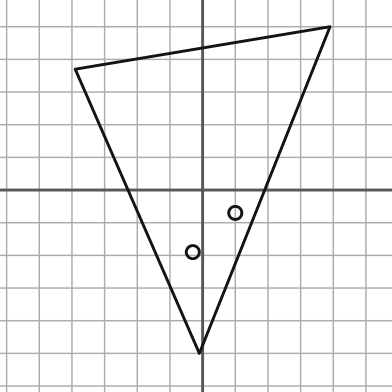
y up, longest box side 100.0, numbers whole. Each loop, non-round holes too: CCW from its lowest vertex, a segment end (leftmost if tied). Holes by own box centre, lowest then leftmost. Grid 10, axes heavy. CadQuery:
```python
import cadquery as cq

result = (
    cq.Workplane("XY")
    .moveTo(-1.0, -50.0)
    .lineTo(39.0, 50.0)
    .lineTo(-39.0, 37.0)
    .close()
    .moveTo(-3.0, -19.0)
    .circle(2.0)
    .moveTo(10.0, -7.0)
    .circle(2.0)
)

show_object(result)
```